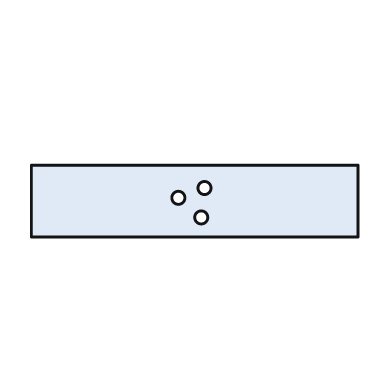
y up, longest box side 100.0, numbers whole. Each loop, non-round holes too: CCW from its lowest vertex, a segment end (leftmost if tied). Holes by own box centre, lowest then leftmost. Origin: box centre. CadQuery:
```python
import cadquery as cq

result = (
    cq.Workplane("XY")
    .moveTo(-50.0, -11.0)
    .lineTo(50.0, -11.0)
    .lineTo(50.0, 11.0)
    .lineTo(-50.0, 11.0)
    .close()
    .moveTo(2.0, -5.0)
    .circle(2.0)
    .moveTo(-5.0, 1.0)
    .circle(2.0)
    .moveTo(3.0, 4.0)
    .circle(2.0)
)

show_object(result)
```